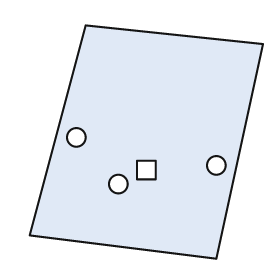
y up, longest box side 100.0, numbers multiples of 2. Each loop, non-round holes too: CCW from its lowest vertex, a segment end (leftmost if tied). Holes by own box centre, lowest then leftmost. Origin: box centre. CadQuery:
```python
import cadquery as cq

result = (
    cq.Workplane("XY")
    .moveTo(30.0, -50.0)
    .lineTo(50.0, 42.0)
    .lineTo(-26.0, 50.0)
    .lineTo(-50.0, -40.0)
    .close()
    .moveTo(-12.0, -18.0)
    .circle(4.0)
    .moveTo(-4.0, -16.0)
    .lineTo(4.0, -16.0)
    .lineTo(4.0, -8.0)
    .lineTo(-4.0, -8.0)
    .close()
    .moveTo(30.0, -10.0)
    .circle(4.0)
    .moveTo(-30.0, 2.0)
    .circle(4.0)
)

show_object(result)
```